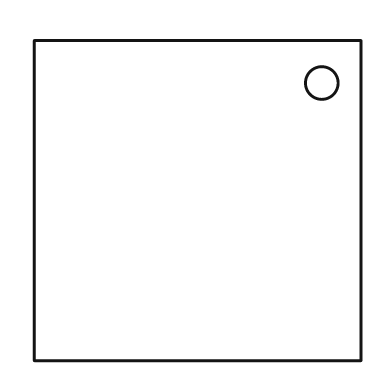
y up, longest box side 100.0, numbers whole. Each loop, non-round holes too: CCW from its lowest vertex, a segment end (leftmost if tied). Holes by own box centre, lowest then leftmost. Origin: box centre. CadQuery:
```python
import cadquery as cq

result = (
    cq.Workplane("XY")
    .moveTo(-50.0, -49.0)
    .lineTo(50.0, -49.0)
    .lineTo(50.0, 49.0)
    .lineTo(-50.0, 49.0)
    .close()
    .moveTo(38.0, 36.0)
    .circle(5.0)
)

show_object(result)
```